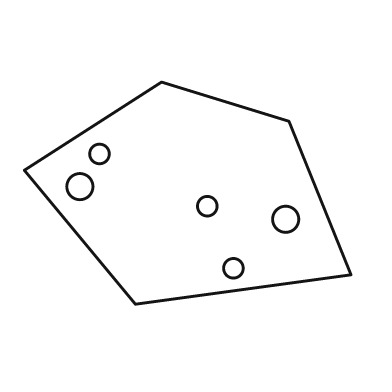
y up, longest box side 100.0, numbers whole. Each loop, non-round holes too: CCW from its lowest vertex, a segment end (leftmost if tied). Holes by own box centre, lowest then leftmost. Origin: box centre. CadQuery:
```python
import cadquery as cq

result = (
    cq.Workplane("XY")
    .moveTo(-16.0, -34.0)
    .lineTo(50.0, -25.0)
    .lineTo(31.0, 22.0)
    .lineTo(-8.0, 34.0)
    .lineTo(-50.0, 7.0)
    .close()
    .moveTo(14.0, -23.0)
    .circle(3.0)
    .moveTo(30.0, -8.0)
    .circle(4.0)
    .moveTo(6.0, -4.0)
    .circle(3.0)
    .moveTo(-33.0, 2.0)
    .circle(4.0)
    .moveTo(-27.0, 12.0)
    .circle(3.0)
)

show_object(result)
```